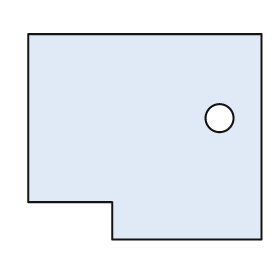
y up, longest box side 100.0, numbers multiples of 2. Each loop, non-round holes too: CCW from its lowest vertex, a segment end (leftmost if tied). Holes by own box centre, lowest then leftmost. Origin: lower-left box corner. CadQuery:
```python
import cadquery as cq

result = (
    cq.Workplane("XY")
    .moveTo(36.0, 0.0)
    .lineTo(100.0, 0.0)
    .lineTo(100.0, 88.0)
    .lineTo(0.0, 88.0)
    .lineTo(0.0, 16.0)
    .lineTo(36.0, 16.0)
    .close()
    .moveTo(82.0, 52.0)
    .circle(6.0)
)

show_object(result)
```